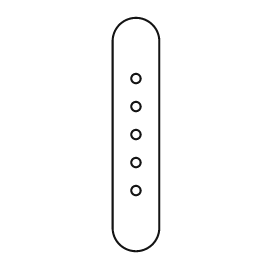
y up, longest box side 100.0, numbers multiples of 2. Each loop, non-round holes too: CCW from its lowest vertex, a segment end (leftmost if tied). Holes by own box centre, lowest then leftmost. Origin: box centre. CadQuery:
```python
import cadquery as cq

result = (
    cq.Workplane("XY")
    .moveTo(-10.0, -40.0)
    .threePointArc((0.0, -50.0), (10.0, -40.0))
    .lineTo(10.0, 40.0)
    .threePointArc((0.0, 50.0), (-10.0, 40.0))
    .close()
    .moveTo(0.0, -24.0)
    .circle(2.0)
    .moveTo(0.0, -12.0)
    .circle(2.0)
    .moveTo(0.0, 0.0)
    .circle(2.0)
    .moveTo(0.0, 12.0)
    .circle(2.0)
    .moveTo(0.0, 24.0)
    .circle(2.0)
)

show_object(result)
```